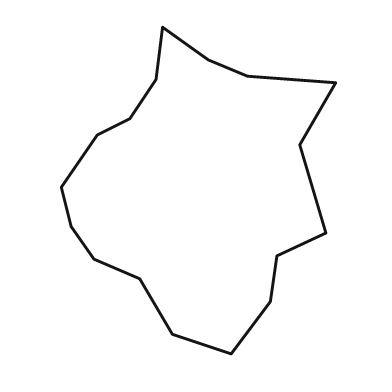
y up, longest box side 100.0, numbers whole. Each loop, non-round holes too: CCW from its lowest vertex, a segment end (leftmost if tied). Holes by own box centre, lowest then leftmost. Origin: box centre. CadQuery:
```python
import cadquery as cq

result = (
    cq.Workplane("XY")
    .moveTo(10.0, -50.0)
    .lineTo(22.0, -34.0)
    .lineTo(24.0, -20.0)
    .lineTo(39.0, -13.0)
    .lineTo(31.0, 14.0)
    .lineTo(42.0, 33.0)
    .lineTo(15.0, 35.0)
    .lineTo(3.0, 40.0)
    .lineTo(-11.0, 50.0)
    .lineTo(-13.0, 34.0)
    .lineTo(-21.0, 22.0)
    .lineTo(-31.0, 17.0)
    .lineTo(-42.0, 1.0)
    .lineTo(-39.0, -11.0)
    .lineTo(-32.0, -21.0)
    .lineTo(-18.0, -27.0)
    .lineTo(-8.0, -44.0)
    .close()
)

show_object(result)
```